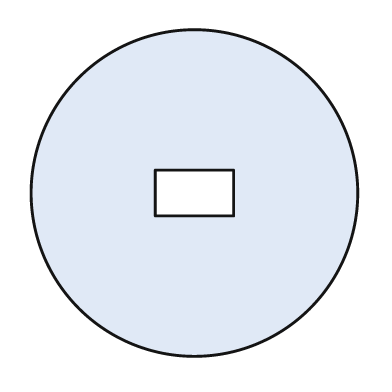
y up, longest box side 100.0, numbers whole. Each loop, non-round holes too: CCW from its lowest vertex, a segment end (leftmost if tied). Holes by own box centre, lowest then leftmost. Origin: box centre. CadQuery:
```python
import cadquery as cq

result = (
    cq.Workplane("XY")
    .moveTo(0.0, 0.0)
    .circle(50.0)
    .moveTo(-12.0, -7.0)
    .lineTo(12.0, -7.0)
    .lineTo(12.0, 7.0)
    .lineTo(-12.0, 7.0)
    .close()
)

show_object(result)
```